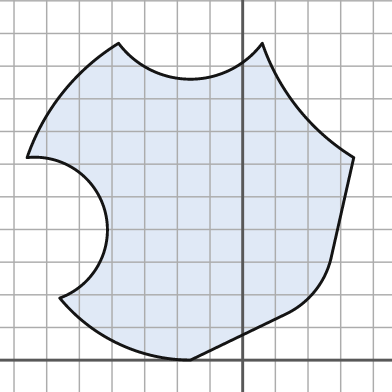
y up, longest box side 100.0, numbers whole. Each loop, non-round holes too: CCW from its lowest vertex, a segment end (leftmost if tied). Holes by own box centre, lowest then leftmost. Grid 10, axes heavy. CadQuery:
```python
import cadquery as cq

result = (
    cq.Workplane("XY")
    .moveTo(-16.0, 0.0)
    .lineTo(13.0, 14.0)
    .threePointArc((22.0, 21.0), (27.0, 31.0))
    .lineTo(34.0, 62.0)
    .threePointArc((17.0, 77.0), (6.0, 97.0))
    .threePointArc((-16.0, 86.0), (-38.0, 97.0))
    .threePointArc((-55.0, 82.0), (-66.0, 62.0))
    .threePointArc((-42.0, 45.0), (-56.0, 19.0))
    .threePointArc((-38.0, 5.0), (-16.0, 0.0))
    .close()
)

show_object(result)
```